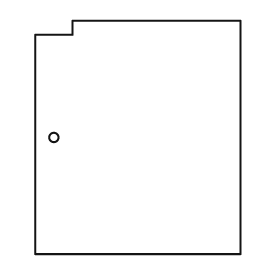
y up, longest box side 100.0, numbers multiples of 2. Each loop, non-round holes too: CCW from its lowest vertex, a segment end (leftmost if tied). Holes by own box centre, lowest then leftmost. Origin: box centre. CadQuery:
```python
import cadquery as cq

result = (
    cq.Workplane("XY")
    .moveTo(-44.0, -50.0)
    .lineTo(44.0, -50.0)
    .lineTo(44.0, 50.0)
    .lineTo(-28.0, 50.0)
    .lineTo(-28.0, 44.0)
    .lineTo(-44.0, 44.0)
    .close()
    .moveTo(-36.0, 0.0)
    .circle(2.0)
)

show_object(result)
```